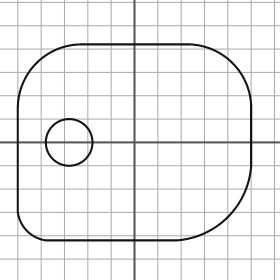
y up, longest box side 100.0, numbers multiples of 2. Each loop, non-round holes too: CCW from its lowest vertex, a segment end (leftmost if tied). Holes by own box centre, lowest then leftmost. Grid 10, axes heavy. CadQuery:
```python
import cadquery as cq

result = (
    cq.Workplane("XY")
    .moveTo(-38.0, -42.0)
    .lineTo(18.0, -42.0)
    .threePointArc((40.0, -32.0), (50.0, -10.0))
    .lineTo(50.0, 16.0)
    .threePointArc((42.0, 34.0), (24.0, 42.0))
    .lineTo(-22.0, 42.0)
    .threePointArc((-42.0, 34.0), (-50.0, 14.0))
    .lineTo(-50.0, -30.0)
    .threePointArc((-46.0, -38.0), (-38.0, -42.0))
    .close()
    .moveTo(-28.0, 0.0)
    .circle(10.0)
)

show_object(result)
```